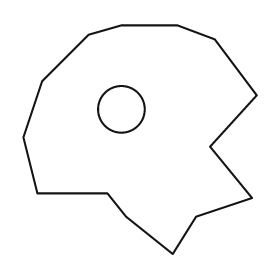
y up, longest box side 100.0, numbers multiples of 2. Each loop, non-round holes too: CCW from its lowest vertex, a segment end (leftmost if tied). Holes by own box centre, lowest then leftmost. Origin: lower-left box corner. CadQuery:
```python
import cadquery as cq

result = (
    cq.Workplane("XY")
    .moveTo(64.0, 0.0)
    .lineTo(74.0, 16.0)
    .lineTo(98.0, 24.0)
    .lineTo(80.0, 46.0)
    .lineTo(100.0, 68.0)
    .lineTo(82.0, 92.0)
    .lineTo(66.0, 98.0)
    .lineTo(42.0, 98.0)
    .lineTo(28.0, 94.0)
    .lineTo(8.0, 74.0)
    .lineTo(0.0, 50.0)
    .lineTo(6.0, 26.0)
    .lineTo(36.0, 26.0)
    .lineTo(44.0, 16.0)
    .close()
    .moveTo(42.0, 62.0)
    .circle(10.0)
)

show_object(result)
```